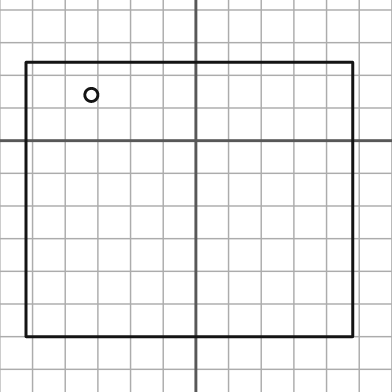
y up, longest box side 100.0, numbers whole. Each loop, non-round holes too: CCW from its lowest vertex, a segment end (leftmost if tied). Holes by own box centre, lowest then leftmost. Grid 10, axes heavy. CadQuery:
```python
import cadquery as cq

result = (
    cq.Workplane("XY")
    .moveTo(-52.0, -60.0)
    .lineTo(48.0, -60.0)
    .lineTo(48.0, 24.0)
    .lineTo(-52.0, 24.0)
    .close()
    .moveTo(-32.0, 14.0)
    .circle(2.0)
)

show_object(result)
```